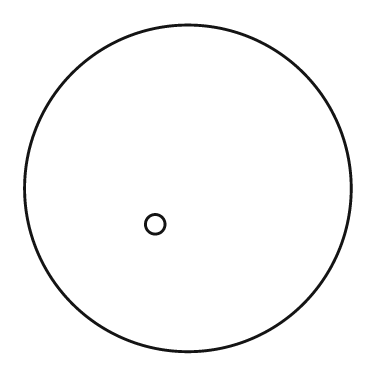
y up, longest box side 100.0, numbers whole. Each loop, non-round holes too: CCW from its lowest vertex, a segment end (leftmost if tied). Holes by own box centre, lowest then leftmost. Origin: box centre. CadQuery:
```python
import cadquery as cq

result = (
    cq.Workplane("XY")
    .moveTo(0.0, 0.0)
    .circle(50.0)
    .moveTo(-10.0, -11.0)
    .circle(3.0)
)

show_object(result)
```